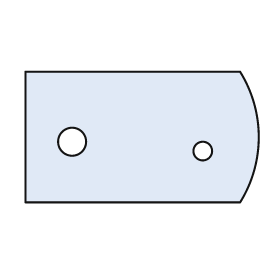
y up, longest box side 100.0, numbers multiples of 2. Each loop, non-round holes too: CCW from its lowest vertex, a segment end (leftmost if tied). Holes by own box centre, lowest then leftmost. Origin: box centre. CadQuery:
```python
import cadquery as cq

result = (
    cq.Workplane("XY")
    .moveTo(-50.0, -28.0)
    .lineTo(42.0, -28.0)
    .threePointArc((50.0, 0.0), (42.0, 28.0))
    .lineTo(-50.0, 28.0)
    .close()
    .moveTo(26.0, -6.0)
    .circle(4.0)
    .moveTo(-30.0, -2.0)
    .circle(6.0)
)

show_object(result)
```